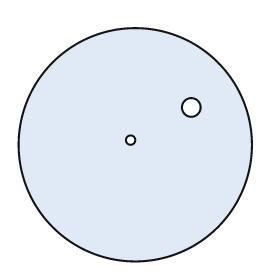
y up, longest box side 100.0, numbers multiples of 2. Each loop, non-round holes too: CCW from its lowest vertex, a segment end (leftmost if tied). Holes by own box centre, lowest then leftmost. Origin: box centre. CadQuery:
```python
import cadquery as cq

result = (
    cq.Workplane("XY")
    .moveTo(0.0, 0.0)
    .circle(50.0)
    .moveTo(-2.0, 2.0)
    .circle(2.0)
    .moveTo(24.0, 16.0)
    .circle(4.0)
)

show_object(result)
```